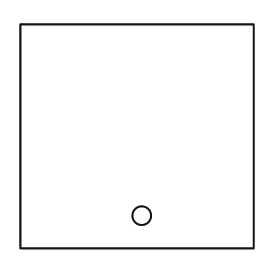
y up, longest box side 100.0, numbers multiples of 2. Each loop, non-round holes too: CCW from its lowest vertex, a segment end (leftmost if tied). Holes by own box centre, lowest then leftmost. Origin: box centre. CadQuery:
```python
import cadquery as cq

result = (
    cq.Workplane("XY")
    .moveTo(-50.0, -48.0)
    .lineTo(50.0, -48.0)
    .lineTo(50.0, 48.0)
    .lineTo(-50.0, 48.0)
    .close()
    .moveTo(2.0, -34.0)
    .circle(4.0)
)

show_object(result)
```